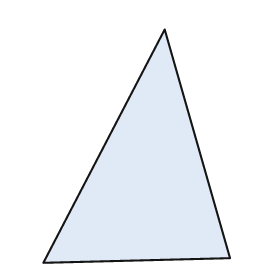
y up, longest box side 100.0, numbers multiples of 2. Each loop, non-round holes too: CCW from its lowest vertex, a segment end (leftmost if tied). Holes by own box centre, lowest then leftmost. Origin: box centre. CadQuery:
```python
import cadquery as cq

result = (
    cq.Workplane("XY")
    .moveTo(-40.0, -50.0)
    .lineTo(40.0, -48.0)
    .lineTo(12.0, 50.0)
    .close()
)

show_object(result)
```